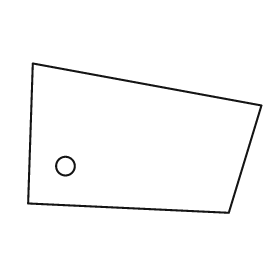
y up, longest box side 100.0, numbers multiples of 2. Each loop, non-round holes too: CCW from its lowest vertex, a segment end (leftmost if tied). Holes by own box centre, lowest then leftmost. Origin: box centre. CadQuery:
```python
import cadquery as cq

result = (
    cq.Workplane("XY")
    .moveTo(36.0, -32.0)
    .lineTo(50.0, 14.0)
    .lineTo(-48.0, 32.0)
    .lineTo(-50.0, -28.0)
    .close()
    .moveTo(-34.0, -12.0)
    .circle(4.0)
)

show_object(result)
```